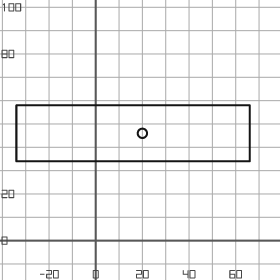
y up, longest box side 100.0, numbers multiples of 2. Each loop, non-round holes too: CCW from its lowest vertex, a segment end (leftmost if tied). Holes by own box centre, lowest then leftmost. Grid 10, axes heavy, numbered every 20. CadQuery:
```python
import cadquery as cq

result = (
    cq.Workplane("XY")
    .moveTo(-34.0, 34.0)
    .lineTo(66.0, 34.0)
    .lineTo(66.0, 58.0)
    .lineTo(-34.0, 58.0)
    .close()
    .moveTo(20.0, 46.0)
    .circle(2.0)
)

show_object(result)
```